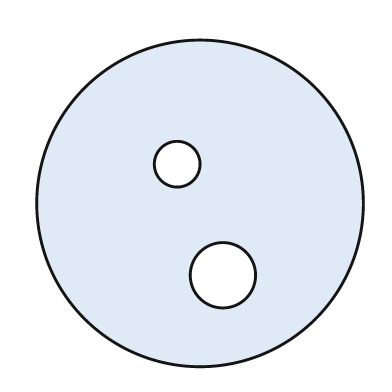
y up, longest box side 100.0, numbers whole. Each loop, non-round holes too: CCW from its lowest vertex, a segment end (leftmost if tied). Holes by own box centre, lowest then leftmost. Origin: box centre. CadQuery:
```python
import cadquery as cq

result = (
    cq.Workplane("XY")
    .moveTo(0.0, 0.0)
    .circle(50.0)
    .moveTo(7.0, -22.0)
    .circle(10.0)
    .moveTo(-7.0, 12.0)
    .circle(7.0)
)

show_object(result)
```